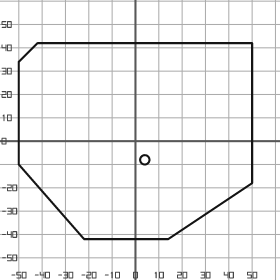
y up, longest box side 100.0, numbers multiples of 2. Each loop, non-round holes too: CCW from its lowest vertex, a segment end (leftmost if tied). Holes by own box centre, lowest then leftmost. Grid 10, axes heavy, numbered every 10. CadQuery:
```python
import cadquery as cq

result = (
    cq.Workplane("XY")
    .moveTo(-22.0, -42.0)
    .lineTo(14.0, -42.0)
    .lineTo(50.0, -18.0)
    .lineTo(50.0, 42.0)
    .lineTo(-42.0, 42.0)
    .lineTo(-50.0, 34.0)
    .lineTo(-50.0, -10.0)
    .close()
    .moveTo(4.0, -8.0)
    .circle(2.0)
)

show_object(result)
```